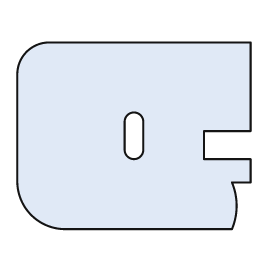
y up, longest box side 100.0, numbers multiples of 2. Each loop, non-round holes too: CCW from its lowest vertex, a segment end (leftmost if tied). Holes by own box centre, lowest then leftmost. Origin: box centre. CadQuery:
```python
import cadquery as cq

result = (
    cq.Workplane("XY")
    .moveTo(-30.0, -40.0)
    .lineTo(42.0, -40.0)
    .threePointArc((44.0, -30.0), (42.0, -20.0))
    .lineTo(50.0, -20.0)
    .lineTo(50.0, -10.0)
    .lineTo(30.0, -10.0)
    .lineTo(30.0, 2.0)
    .lineTo(50.0, 2.0)
    .lineTo(50.0, 40.0)
    .lineTo(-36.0, 40.0)
    .threePointArc((-46.0, 36.0), (-50.0, 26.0))
    .lineTo(-50.0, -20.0)
    .threePointArc((-44.0, -34.0), (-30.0, -40.0))
    .close()
    .moveTo(-4.0, -6.0)
    .threePointArc((0.0, -10.0), (4.0, -6.0))
    .lineTo(4.0, 6.0)
    .threePointArc((0.0, 10.0), (-4.0, 6.0))
    .close()
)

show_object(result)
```